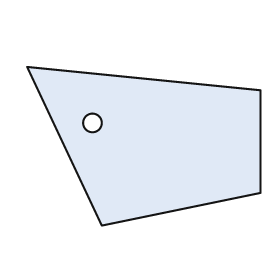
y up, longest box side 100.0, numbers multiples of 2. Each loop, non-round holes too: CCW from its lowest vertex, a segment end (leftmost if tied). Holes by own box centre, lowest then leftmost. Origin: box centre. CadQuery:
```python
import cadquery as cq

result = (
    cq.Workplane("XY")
    .moveTo(-18.0, -34.0)
    .lineTo(50.0, -20.0)
    .lineTo(50.0, 24.0)
    .lineTo(-50.0, 34.0)
    .close()
    .moveTo(-22.0, 10.0)
    .circle(4.0)
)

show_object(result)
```